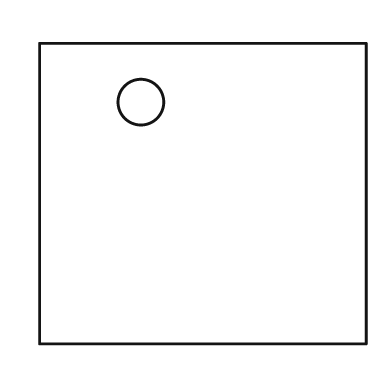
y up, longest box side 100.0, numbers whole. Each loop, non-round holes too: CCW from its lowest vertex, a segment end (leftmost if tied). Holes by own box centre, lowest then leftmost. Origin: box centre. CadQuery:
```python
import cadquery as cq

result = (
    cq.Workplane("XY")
    .moveTo(-50.0, -46.0)
    .lineTo(50.0, -46.0)
    .lineTo(50.0, 46.0)
    .lineTo(-50.0, 46.0)
    .close()
    .moveTo(-19.0, 28.0)
    .circle(7.0)
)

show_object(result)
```